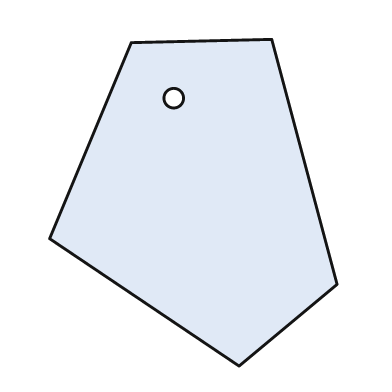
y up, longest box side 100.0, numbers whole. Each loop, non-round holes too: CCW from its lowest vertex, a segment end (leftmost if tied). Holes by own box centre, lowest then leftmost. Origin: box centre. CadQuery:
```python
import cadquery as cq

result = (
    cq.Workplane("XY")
    .moveTo(14.0, -50.0)
    .lineTo(44.0, -25.0)
    .lineTo(24.0, 50.0)
    .lineTo(-19.0, 49.0)
    .lineTo(-44.0, -11.0)
    .close()
    .moveTo(-6.0, 32.0)
    .circle(3.0)
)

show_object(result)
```